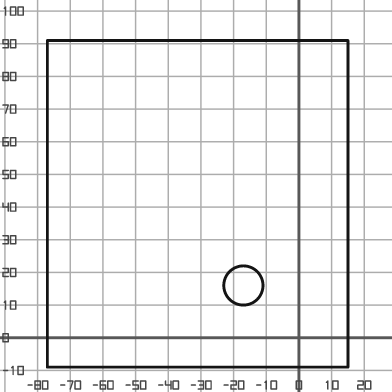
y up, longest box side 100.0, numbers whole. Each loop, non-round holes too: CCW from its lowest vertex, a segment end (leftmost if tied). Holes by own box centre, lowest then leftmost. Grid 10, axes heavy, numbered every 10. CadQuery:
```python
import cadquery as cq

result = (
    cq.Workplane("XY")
    .moveTo(-77.0, -9.0)
    .lineTo(15.0, -9.0)
    .lineTo(15.0, 91.0)
    .lineTo(-77.0, 91.0)
    .close()
    .moveTo(-17.0, 16.0)
    .circle(6.0)
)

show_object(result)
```